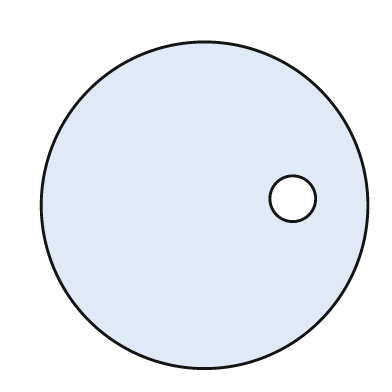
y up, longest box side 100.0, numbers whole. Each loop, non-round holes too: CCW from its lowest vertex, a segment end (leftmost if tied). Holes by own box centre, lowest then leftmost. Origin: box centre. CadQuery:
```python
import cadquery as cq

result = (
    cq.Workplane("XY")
    .moveTo(0.0, 0.0)
    .circle(50.0)
    .moveTo(27.0, 2.0)
    .circle(7.0)
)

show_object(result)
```